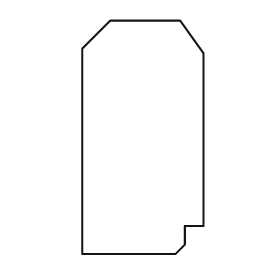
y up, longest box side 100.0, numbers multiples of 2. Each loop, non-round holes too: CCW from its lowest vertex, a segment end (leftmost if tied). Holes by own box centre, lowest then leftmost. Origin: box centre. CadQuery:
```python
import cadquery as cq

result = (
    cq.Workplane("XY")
    .moveTo(-26.0, -50.0)
    .lineTo(14.0, -50.0)
    .lineTo(18.0, -46.0)
    .lineTo(18.0, -38.0)
    .lineTo(26.0, -38.0)
    .lineTo(26.0, 36.0)
    .lineTo(16.0, 50.0)
    .lineTo(-14.0, 50.0)
    .lineTo(-26.0, 38.0)
    .close()
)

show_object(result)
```